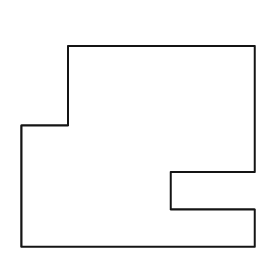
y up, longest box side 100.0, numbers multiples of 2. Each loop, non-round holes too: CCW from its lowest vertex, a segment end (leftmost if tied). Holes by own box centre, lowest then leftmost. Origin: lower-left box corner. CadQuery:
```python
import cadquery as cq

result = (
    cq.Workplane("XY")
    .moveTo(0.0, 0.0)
    .lineTo(100.0, 0.0)
    .lineTo(100.0, 16.0)
    .lineTo(64.0, 16.0)
    .lineTo(64.0, 32.0)
    .lineTo(100.0, 32.0)
    .lineTo(100.0, 86.0)
    .lineTo(20.0, 86.0)
    .lineTo(20.0, 52.0)
    .lineTo(0.0, 52.0)
    .close()
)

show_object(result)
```